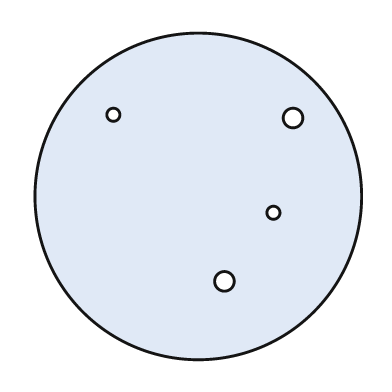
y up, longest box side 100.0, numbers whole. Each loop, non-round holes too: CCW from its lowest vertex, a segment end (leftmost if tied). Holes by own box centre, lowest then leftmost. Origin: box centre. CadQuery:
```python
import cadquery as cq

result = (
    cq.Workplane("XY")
    .moveTo(0.0, 0.0)
    .circle(50.0)
    .moveTo(8.0, -26.0)
    .circle(3.0)
    .moveTo(23.0, -5.0)
    .circle(2.0)
    .moveTo(29.0, 24.0)
    .circle(3.0)
    .moveTo(-26.0, 25.0)
    .circle(2.0)
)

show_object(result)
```